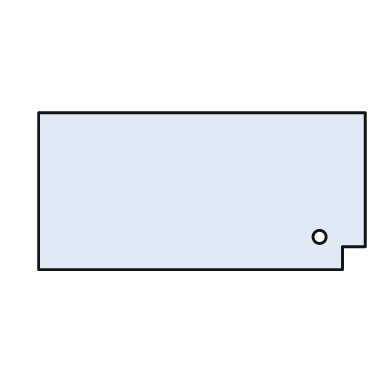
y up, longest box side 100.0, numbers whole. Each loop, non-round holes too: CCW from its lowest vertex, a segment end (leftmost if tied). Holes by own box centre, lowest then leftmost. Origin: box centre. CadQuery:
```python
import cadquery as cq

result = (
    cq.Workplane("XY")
    .moveTo(-50.0, -24.0)
    .lineTo(43.0, -24.0)
    .lineTo(43.0, -17.0)
    .lineTo(50.0, -17.0)
    .lineTo(50.0, 24.0)
    .lineTo(-50.0, 24.0)
    .close()
    .moveTo(36.0, -14.0)
    .circle(2.0)
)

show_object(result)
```